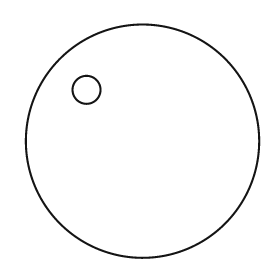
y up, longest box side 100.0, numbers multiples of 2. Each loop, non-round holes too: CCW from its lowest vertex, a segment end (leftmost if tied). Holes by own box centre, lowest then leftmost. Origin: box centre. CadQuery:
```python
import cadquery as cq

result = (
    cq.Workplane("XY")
    .moveTo(0.0, 0.0)
    .circle(50.0)
    .moveTo(-24.0, 22.0)
    .circle(6.0)
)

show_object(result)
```